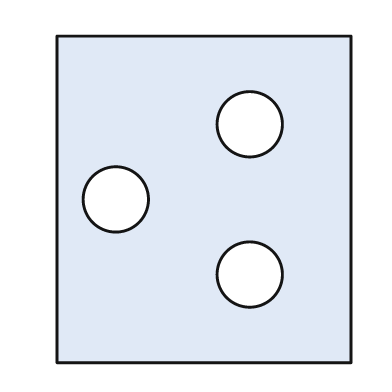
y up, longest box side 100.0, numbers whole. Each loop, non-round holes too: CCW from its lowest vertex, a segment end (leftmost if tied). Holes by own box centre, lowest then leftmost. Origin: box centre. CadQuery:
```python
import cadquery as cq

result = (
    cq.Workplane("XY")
    .moveTo(-45.0, -50.0)
    .lineTo(45.0, -50.0)
    .lineTo(45.0, 50.0)
    .lineTo(-45.0, 50.0)
    .close()
    .moveTo(14.0, -23.0)
    .circle(10.0)
    .moveTo(-27.0, 0.0)
    .circle(10.0)
    .moveTo(14.0, 23.0)
    .circle(10.0)
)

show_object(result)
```